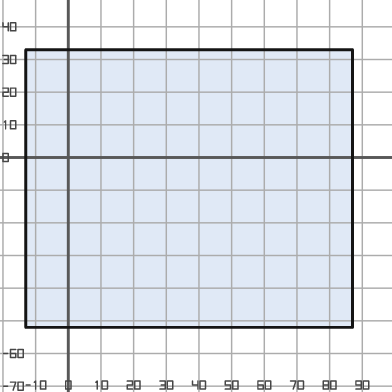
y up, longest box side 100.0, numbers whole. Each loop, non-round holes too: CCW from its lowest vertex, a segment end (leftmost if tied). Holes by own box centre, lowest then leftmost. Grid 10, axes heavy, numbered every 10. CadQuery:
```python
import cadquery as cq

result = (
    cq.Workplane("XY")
    .moveTo(-13.0, -52.0)
    .lineTo(87.0, -52.0)
    .lineTo(87.0, 33.0)
    .lineTo(-13.0, 33.0)
    .close()
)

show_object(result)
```